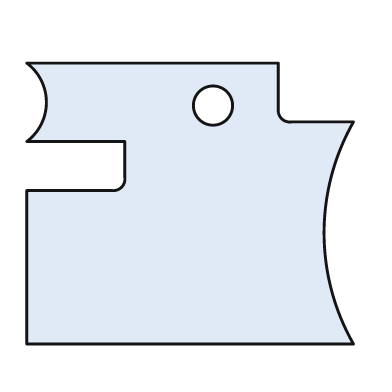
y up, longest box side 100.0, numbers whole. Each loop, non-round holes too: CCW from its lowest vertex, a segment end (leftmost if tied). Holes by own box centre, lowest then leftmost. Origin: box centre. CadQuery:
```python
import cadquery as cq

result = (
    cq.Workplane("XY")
    .moveTo(-50.0, -43.0)
    .lineTo(50.0, -43.0)
    .threePointArc((41.0, -9.0), (50.0, 25.0))
    .lineTo(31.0, 25.0)
    .threePointArc((28.0, 26.0), (27.0, 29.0))
    .lineTo(27.0, 43.0)
    .lineTo(-50.0, 43.0)
    .threePointArc((-44.0, 31.0), (-50.0, 19.0))
    .lineTo(-20.0, 19.0)
    .lineTo(-20.0, 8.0)
    .threePointArc((-21.0, 5.0), (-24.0, 4.0))
    .lineTo(-50.0, 4.0)
    .close()
    .moveTo(7.0, 30.0)
    .circle(6.0)
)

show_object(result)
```